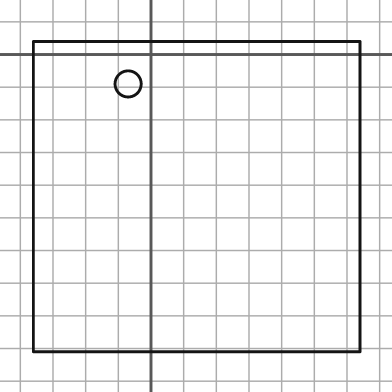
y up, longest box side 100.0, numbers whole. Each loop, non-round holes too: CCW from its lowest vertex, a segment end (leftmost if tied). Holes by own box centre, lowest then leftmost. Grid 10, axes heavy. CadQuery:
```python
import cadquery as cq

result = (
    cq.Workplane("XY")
    .moveTo(-36.0, -91.0)
    .lineTo(64.0, -91.0)
    .lineTo(64.0, 4.0)
    .lineTo(-36.0, 4.0)
    .close()
    .moveTo(-7.0, -9.0)
    .circle(4.0)
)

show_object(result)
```